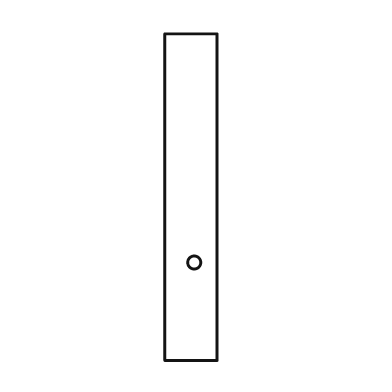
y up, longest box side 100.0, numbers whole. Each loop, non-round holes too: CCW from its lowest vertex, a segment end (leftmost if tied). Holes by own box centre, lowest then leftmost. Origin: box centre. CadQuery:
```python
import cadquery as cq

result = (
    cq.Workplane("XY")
    .moveTo(-8.0, -50.0)
    .lineTo(8.0, -50.0)
    .lineTo(8.0, 50.0)
    .lineTo(-8.0, 50.0)
    .close()
    .moveTo(1.0, -20.0)
    .circle(2.0)
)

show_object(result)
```